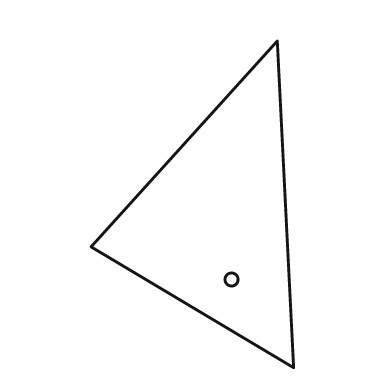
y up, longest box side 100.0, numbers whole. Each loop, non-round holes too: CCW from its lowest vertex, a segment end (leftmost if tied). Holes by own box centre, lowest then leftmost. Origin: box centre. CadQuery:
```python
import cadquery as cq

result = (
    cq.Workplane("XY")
    .moveTo(31.0, -50.0)
    .lineTo(26.0, 50.0)
    .lineTo(-31.0, -13.0)
    .close()
    .moveTo(12.0, -23.0)
    .circle(2.0)
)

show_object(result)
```